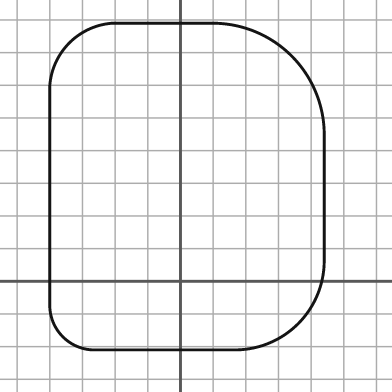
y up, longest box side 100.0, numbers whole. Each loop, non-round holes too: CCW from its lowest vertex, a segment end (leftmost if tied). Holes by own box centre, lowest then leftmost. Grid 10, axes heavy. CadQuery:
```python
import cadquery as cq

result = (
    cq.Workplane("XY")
    .moveTo(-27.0, -21.0)
    .lineTo(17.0, -21.0)
    .threePointArc((36.0, -13.0), (44.0, 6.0))
    .lineTo(44.0, 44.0)
    .threePointArc((34.0, 69.0), (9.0, 79.0))
    .lineTo(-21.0, 79.0)
    .threePointArc((-34.0, 73.0), (-40.0, 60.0))
    .lineTo(-40.0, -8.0)
    .threePointArc((-36.0, -17.0), (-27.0, -21.0))
    .close()
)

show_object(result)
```